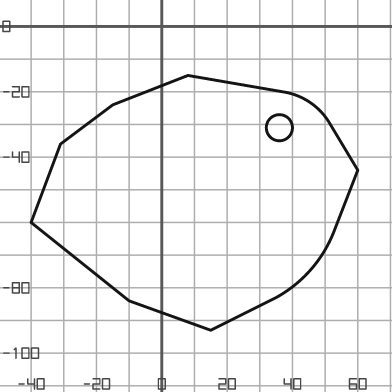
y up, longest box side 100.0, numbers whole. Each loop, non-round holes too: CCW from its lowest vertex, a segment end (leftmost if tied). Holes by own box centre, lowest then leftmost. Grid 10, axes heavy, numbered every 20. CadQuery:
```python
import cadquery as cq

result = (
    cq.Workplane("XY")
    .moveTo(15.0, -93.0)
    .lineTo(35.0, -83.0)
    .threePointArc((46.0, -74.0), (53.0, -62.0))
    .lineTo(60.0, -44.0)
    .lineTo(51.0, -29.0)
    .threePointArc((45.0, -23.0), (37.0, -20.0))
    .lineTo(8.0, -15.0)
    .lineTo(-15.0, -24.0)
    .lineTo(-31.0, -36.0)
    .lineTo(-40.0, -60.0)
    .lineTo(-10.0, -84.0)
    .close()
    .moveTo(36.0, -31.0)
    .circle(4.0)
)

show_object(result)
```